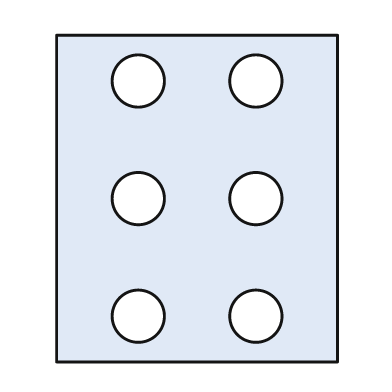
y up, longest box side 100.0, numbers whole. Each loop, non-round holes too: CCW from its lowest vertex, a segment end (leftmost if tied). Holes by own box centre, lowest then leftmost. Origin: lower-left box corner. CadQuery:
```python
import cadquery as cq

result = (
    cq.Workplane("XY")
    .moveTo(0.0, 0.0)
    .lineTo(86.0, 0.0)
    .lineTo(86.0, 100.0)
    .lineTo(0.0, 100.0)
    .close()
    .moveTo(25.0, 14.0)
    .circle(8.0)
    .moveTo(61.0, 14.0)
    .circle(8.0)
    .moveTo(25.0, 50.0)
    .circle(8.0)
    .moveTo(61.0, 50.0)
    .circle(8.0)
    .moveTo(25.0, 86.0)
    .circle(8.0)
    .moveTo(61.0, 86.0)
    .circle(8.0)
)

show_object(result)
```